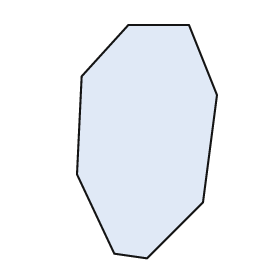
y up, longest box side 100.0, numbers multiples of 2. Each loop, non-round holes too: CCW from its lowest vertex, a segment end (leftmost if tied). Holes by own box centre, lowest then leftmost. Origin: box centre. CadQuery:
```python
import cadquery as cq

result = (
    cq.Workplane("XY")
    .moveTo(0.0, -50.0)
    .lineTo(24.0, -26.0)
    .lineTo(30.0, 20.0)
    .lineTo(18.0, 50.0)
    .lineTo(-8.0, 50.0)
    .lineTo(-28.0, 28.0)
    .lineTo(-30.0, -14.0)
    .lineTo(-14.0, -48.0)
    .close()
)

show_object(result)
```